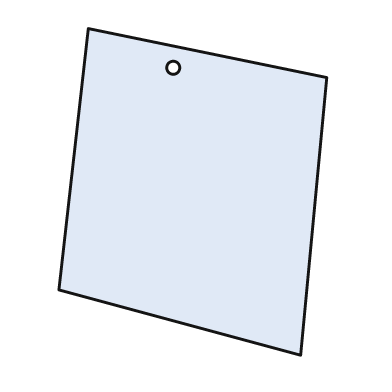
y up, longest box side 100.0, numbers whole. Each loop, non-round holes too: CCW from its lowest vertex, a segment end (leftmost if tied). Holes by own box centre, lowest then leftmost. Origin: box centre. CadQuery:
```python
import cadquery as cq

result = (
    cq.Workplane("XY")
    .moveTo(33.0, -50.0)
    .lineTo(41.0, 35.0)
    .lineTo(-32.0, 50.0)
    .lineTo(-41.0, -30.0)
    .close()
    .moveTo(-6.0, 38.0)
    .circle(2.0)
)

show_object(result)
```